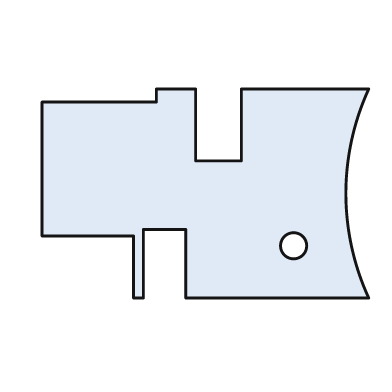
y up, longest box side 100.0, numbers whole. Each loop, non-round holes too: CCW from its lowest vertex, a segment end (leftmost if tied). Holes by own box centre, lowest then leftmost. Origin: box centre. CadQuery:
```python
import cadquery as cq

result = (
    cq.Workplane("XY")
    .moveTo(-22.0, -32.0)
    .lineTo(-19.0, -32.0)
    .lineTo(-19.0, -11.0)
    .lineTo(-6.0, -11.0)
    .lineTo(-6.0, -32.0)
    .lineTo(50.0, -32.0)
    .threePointArc((43.0, 0.0), (50.0, 32.0))
    .lineTo(11.0, 32.0)
    .lineTo(11.0, 10.0)
    .lineTo(-3.0, 10.0)
    .lineTo(-3.0, 32.0)
    .lineTo(-15.0, 32.0)
    .lineTo(-15.0, 28.0)
    .lineTo(-50.0, 28.0)
    .lineTo(-50.0, -13.0)
    .lineTo(-22.0, -13.0)
    .close()
    .moveTo(27.0, -16.0)
    .circle(4.0)
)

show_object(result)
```